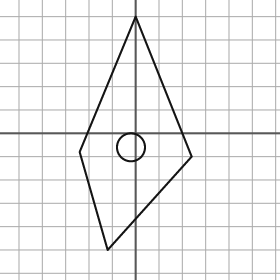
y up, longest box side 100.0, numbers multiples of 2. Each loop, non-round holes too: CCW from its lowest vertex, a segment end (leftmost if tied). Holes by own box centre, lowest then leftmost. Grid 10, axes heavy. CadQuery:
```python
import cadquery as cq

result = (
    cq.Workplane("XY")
    .moveTo(-12.0, -50.0)
    .lineTo(24.0, -10.0)
    .lineTo(0.0, 50.0)
    .lineTo(-24.0, -8.0)
    .close()
    .moveTo(-2.0, -6.0)
    .circle(6.0)
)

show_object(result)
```